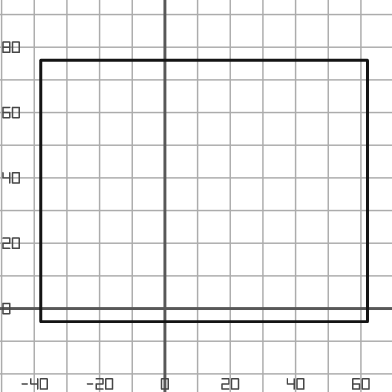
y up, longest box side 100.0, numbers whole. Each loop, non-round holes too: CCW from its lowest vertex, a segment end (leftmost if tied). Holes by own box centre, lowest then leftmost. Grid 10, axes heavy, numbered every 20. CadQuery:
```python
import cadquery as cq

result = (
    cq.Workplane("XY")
    .moveTo(-38.0, -4.0)
    .lineTo(62.0, -4.0)
    .lineTo(62.0, 76.0)
    .lineTo(-38.0, 76.0)
    .close()
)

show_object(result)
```